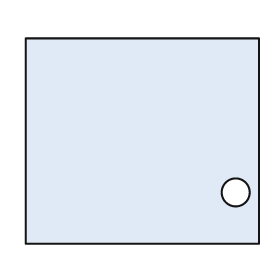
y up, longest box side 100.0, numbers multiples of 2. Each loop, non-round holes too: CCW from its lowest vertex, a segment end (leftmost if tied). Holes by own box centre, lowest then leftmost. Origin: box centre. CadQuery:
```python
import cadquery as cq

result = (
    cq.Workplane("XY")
    .moveTo(-50.0, -44.0)
    .lineTo(50.0, -44.0)
    .lineTo(50.0, 44.0)
    .lineTo(-50.0, 44.0)
    .close()
    .moveTo(40.0, -22.0)
    .circle(6.0)
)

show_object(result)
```